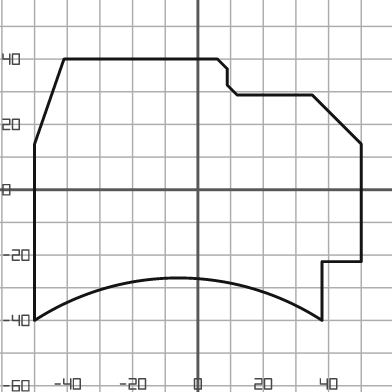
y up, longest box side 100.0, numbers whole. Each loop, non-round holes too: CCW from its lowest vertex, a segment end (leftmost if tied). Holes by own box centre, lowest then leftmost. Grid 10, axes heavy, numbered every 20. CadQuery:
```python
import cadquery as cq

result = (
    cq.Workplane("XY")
    .moveTo(-50.0, -40.0)
    .threePointArc((-6.0, -27.0), (38.0, -40.0))
    .lineTo(38.0, -22.0)
    .lineTo(50.0, -22.0)
    .lineTo(50.0, 14.0)
    .lineTo(35.0, 29.0)
    .lineTo(12.0, 29.0)
    .lineTo(9.0, 32.0)
    .lineTo(9.0, 37.0)
    .lineTo(6.0, 40.0)
    .lineTo(-41.0, 40.0)
    .lineTo(-50.0, 14.0)
    .close()
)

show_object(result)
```